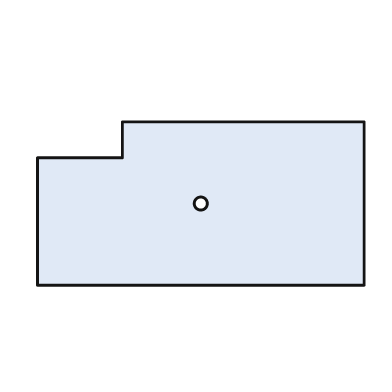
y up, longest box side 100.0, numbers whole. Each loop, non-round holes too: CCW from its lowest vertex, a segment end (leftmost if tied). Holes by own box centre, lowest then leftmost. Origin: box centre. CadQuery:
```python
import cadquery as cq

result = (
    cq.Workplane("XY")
    .moveTo(-50.0, -25.0)
    .lineTo(50.0, -25.0)
    .lineTo(50.0, 25.0)
    .lineTo(-24.0, 25.0)
    .lineTo(-24.0, 14.0)
    .lineTo(-50.0, 14.0)
    .close()
    .moveTo(0.0, 0.0)
    .circle(2.0)
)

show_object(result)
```